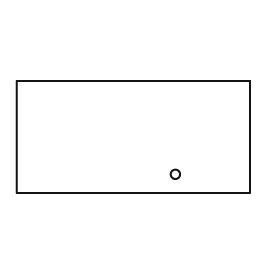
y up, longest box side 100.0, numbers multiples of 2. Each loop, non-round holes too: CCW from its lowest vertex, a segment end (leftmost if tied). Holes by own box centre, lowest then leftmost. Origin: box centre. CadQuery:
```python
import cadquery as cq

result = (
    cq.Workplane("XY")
    .moveTo(-50.0, -24.0)
    .lineTo(50.0, -24.0)
    .lineTo(50.0, 24.0)
    .lineTo(-50.0, 24.0)
    .close()
    .moveTo(18.0, -16.0)
    .circle(2.0)
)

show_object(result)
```